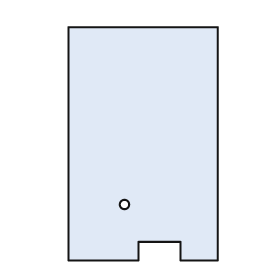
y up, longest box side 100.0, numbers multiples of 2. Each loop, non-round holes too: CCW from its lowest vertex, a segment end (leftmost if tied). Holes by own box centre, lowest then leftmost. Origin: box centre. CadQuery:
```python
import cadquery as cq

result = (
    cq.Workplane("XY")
    .moveTo(-32.0, -50.0)
    .lineTo(-2.0, -50.0)
    .lineTo(-2.0, -42.0)
    .lineTo(16.0, -42.0)
    .lineTo(16.0, -50.0)
    .lineTo(32.0, -50.0)
    .lineTo(32.0, 50.0)
    .lineTo(-32.0, 50.0)
    .close()
    .moveTo(-8.0, -26.0)
    .circle(2.0)
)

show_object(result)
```